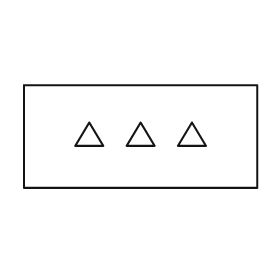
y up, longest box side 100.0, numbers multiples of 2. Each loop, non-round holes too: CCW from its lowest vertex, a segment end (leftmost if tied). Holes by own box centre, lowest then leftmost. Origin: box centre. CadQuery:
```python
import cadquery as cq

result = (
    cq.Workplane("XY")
    .moveTo(-50.0, -22.0)
    .lineTo(50.0, -22.0)
    .lineTo(50.0, 22.0)
    .lineTo(-50.0, 22.0)
    .close()
    .moveTo(-28.0, -4.0)
    .lineTo(-16.0, -4.0)
    .lineTo(-22.0, 6.0)
    .close()
    .moveTo(-6.0, -4.0)
    .lineTo(6.0, -4.0)
    .lineTo(0.0, 6.0)
    .close()
    .moveTo(16.0, -4.0)
    .lineTo(28.0, -4.0)
    .lineTo(22.0, 6.0)
    .close()
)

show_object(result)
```